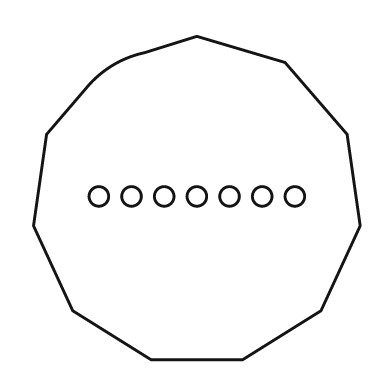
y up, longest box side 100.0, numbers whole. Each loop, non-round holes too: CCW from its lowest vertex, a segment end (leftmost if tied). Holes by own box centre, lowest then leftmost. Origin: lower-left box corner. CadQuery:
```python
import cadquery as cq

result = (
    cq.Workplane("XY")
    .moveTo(36.0, 0.0)
    .lineTo(64.0, 0.0)
    .lineTo(88.0, 15.0)
    .lineTo(100.0, 41.0)
    .lineTo(96.0, 69.0)
    .lineTo(77.0, 91.0)
    .lineTo(50.0, 99.0)
    .lineTo(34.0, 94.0)
    .threePointArc((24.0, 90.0), (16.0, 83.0))
    .lineTo(4.0, 69.0)
    .lineTo(0.0, 41.0)
    .lineTo(12.0, 15.0)
    .close()
    .moveTo(20.0, 50.0)
    .circle(3.0)
    .moveTo(30.0, 50.0)
    .circle(3.0)
    .moveTo(40.0, 50.0)
    .circle(3.0)
    .moveTo(50.0, 50.0)
    .circle(3.0)
    .moveTo(60.0, 50.0)
    .circle(3.0)
    .moveTo(70.0, 50.0)
    .circle(3.0)
    .moveTo(80.0, 50.0)
    .circle(3.0)
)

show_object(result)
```